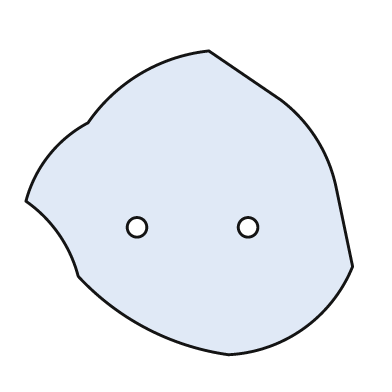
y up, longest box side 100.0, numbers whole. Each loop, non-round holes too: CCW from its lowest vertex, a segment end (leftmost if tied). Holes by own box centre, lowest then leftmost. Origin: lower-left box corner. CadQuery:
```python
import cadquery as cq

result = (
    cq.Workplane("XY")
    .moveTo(62.0, 0.0)
    .threePointArc((85.0, 8.0), (100.0, 27.0))
    .lineTo(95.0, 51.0)
    .threePointArc((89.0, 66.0), (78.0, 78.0))
    .lineTo(56.0, 93.0)
    .threePointArc((35.0, 86.0), (19.0, 71.0))
    .threePointArc((7.0, 61.0), (0.0, 47.0))
    .threePointArc((10.0, 37.0), (16.0, 24.0))
    .threePointArc((37.0, 8.0), (62.0, 0.0))
    .close()
    .moveTo(34.0, 39.0)
    .circle(3.0)
    .moveTo(68.0, 39.0)
    .circle(3.0)
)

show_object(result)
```